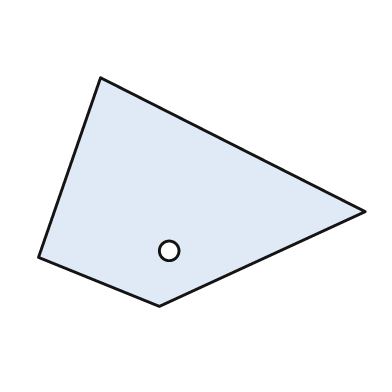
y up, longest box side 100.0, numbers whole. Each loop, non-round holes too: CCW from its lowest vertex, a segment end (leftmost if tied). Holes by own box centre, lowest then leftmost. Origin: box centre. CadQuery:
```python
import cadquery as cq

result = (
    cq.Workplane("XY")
    .moveTo(-13.0, -35.0)
    .lineTo(50.0, -6.0)
    .lineTo(-31.0, 35.0)
    .lineTo(-50.0, -20.0)
    .close()
    .moveTo(-10.0, -18.0)
    .circle(3.0)
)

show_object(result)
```